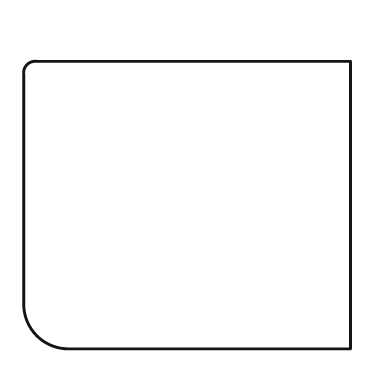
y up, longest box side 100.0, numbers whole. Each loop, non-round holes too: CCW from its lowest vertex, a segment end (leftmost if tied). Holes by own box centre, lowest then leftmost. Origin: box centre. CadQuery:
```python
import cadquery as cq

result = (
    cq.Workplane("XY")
    .moveTo(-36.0, -44.0)
    .lineTo(50.0, -44.0)
    .lineTo(50.0, 44.0)
    .lineTo(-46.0, 44.0)
    .threePointArc((-49.0, 43.0), (-50.0, 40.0))
    .lineTo(-50.0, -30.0)
    .threePointArc((-46.0, -40.0), (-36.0, -44.0))
    .close()
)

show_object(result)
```